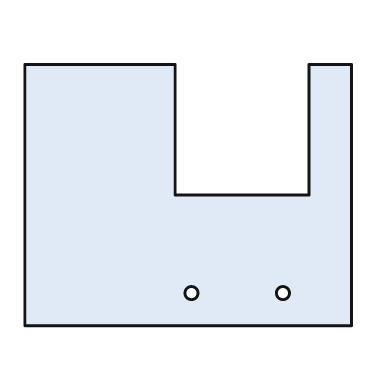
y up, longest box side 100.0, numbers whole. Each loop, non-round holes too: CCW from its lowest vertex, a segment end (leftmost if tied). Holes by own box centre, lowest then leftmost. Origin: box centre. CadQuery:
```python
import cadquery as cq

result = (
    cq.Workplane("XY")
    .moveTo(-50.0, -40.0)
    .lineTo(50.0, -40.0)
    .lineTo(50.0, 40.0)
    .lineTo(37.0, 40.0)
    .lineTo(37.0, 0.0)
    .lineTo(-4.0, 0.0)
    .lineTo(-4.0, 40.0)
    .lineTo(-50.0, 40.0)
    .close()
    .moveTo(1.0, -30.0)
    .circle(2.0)
    .moveTo(29.0, -30.0)
    .circle(2.0)
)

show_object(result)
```